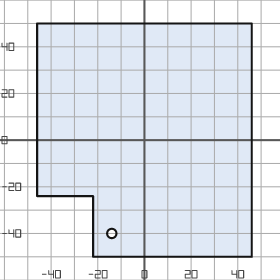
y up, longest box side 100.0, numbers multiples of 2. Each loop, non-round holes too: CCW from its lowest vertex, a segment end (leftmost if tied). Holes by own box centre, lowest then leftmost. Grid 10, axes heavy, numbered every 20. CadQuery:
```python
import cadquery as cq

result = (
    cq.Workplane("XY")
    .moveTo(-22.0, -50.0)
    .lineTo(46.0, -50.0)
    .lineTo(46.0, 50.0)
    .lineTo(-46.0, 50.0)
    .lineTo(-46.0, -24.0)
    .lineTo(-22.0, -24.0)
    .close()
    .moveTo(-14.0, -40.0)
    .circle(2.0)
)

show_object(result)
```